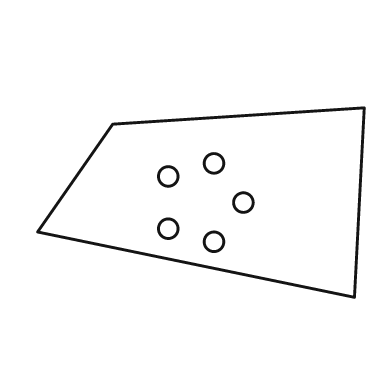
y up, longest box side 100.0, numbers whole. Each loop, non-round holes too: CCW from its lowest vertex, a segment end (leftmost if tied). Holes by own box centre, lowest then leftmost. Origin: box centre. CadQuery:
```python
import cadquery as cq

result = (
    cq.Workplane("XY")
    .moveTo(47.0, -29.0)
    .lineTo(50.0, 29.0)
    .lineTo(-27.0, 24.0)
    .lineTo(-50.0, -9.0)
    .close()
    .moveTo(4.0, -12.0)
    .circle(3.0)
    .moveTo(-10.0, -8.0)
    .circle(3.0)
    .moveTo(13.0, 0.0)
    .circle(3.0)
    .moveTo(-10.0, 8.0)
    .circle(3.0)
    .moveTo(4.0, 12.0)
    .circle(3.0)
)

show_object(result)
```